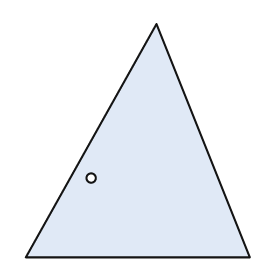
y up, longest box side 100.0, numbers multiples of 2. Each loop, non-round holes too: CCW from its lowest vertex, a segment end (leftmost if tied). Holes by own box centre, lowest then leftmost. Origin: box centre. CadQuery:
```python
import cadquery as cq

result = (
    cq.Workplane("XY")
    .moveTo(-48.0, -50.0)
    .lineTo(48.0, -50.0)
    .lineTo(8.0, 50.0)
    .close()
    .moveTo(-20.0, -16.0)
    .circle(2.0)
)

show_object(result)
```